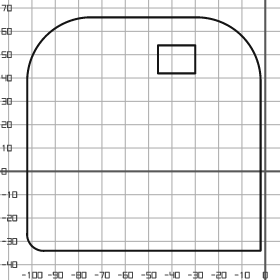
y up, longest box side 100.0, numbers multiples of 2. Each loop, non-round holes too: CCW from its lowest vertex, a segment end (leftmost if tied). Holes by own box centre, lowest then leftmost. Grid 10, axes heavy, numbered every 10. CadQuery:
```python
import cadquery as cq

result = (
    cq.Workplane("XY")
    .moveTo(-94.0, -34.0)
    .lineTo(-2.0, -34.0)
    .lineTo(-2.0, 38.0)
    .threePointArc((-10.0, 58.0), (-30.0, 66.0))
    .lineTo(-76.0, 66.0)
    .threePointArc((-94.0, 58.0), (-102.0, 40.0))
    .lineTo(-102.0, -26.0)
    .threePointArc((-100.0, -32.0), (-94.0, -34.0))
    .close()
    .moveTo(-46.0, 42.0)
    .lineTo(-30.0, 42.0)
    .lineTo(-30.0, 54.0)
    .lineTo(-46.0, 54.0)
    .close()
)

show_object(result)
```